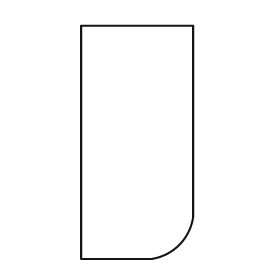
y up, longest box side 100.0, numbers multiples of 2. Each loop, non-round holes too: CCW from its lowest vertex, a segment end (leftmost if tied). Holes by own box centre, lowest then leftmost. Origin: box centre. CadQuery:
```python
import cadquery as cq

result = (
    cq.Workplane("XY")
    .moveTo(-24.0, -50.0)
    .lineTo(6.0, -50.0)
    .threePointArc((18.0, -44.0), (24.0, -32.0))
    .lineTo(24.0, 50.0)
    .lineTo(-24.0, 50.0)
    .close()
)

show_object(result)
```